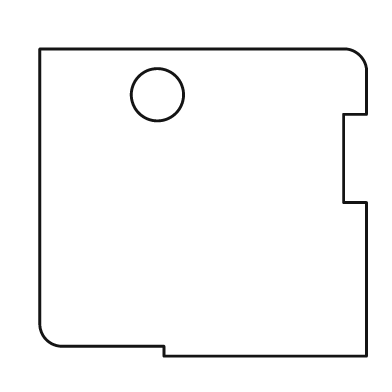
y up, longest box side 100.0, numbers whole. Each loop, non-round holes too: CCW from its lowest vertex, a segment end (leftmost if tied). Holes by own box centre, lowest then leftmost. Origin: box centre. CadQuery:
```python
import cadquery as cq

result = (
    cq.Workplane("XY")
    .moveTo(-12.0, -47.0)
    .lineTo(50.0, -47.0)
    .lineTo(50.0, 0.0)
    .lineTo(43.0, 0.0)
    .lineTo(43.0, 27.0)
    .lineTo(50.0, 27.0)
    .lineTo(50.0, 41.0)
    .threePointArc((48.0, 45.0), (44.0, 47.0))
    .lineTo(-50.0, 47.0)
    .lineTo(-50.0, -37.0)
    .threePointArc((-48.0, -42.0), (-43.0, -44.0))
    .lineTo(-12.0, -44.0)
    .close()
    .moveTo(-14.0, 33.0)
    .circle(8.0)
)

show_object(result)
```